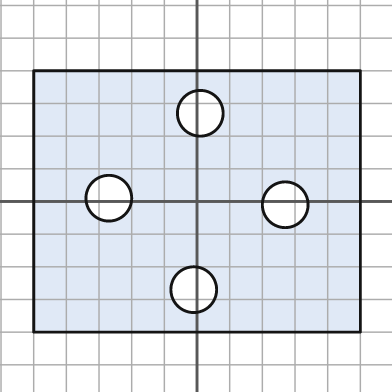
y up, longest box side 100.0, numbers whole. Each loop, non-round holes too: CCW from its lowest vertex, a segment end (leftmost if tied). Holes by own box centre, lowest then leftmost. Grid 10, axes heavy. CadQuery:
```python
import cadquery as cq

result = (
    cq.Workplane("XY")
    .moveTo(-50.0, -40.0)
    .lineTo(50.0, -40.0)
    .lineTo(50.0, 40.0)
    .lineTo(-50.0, 40.0)
    .close()
    .moveTo(-1.0, -27.0)
    .circle(7.0)
    .moveTo(27.0, -1.0)
    .circle(7.0)
    .moveTo(-27.0, 1.0)
    .circle(7.0)
    .moveTo(1.0, 27.0)
    .circle(7.0)
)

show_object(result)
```